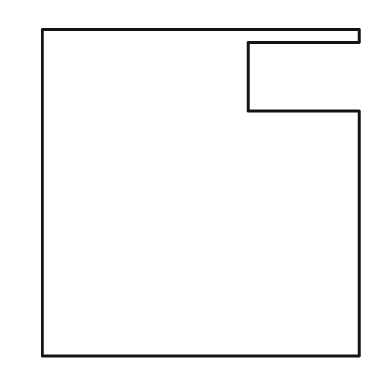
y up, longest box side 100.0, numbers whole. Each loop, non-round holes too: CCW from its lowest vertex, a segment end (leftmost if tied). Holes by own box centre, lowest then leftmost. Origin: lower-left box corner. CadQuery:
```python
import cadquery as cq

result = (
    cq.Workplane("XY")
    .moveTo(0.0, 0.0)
    .lineTo(97.0, 0.0)
    .lineTo(97.0, 75.0)
    .lineTo(63.0, 75.0)
    .lineTo(63.0, 96.0)
    .lineTo(97.0, 96.0)
    .lineTo(97.0, 100.0)
    .lineTo(0.0, 100.0)
    .close()
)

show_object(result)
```